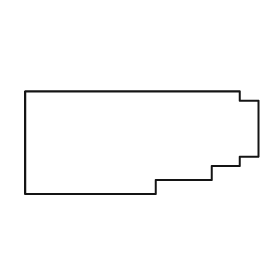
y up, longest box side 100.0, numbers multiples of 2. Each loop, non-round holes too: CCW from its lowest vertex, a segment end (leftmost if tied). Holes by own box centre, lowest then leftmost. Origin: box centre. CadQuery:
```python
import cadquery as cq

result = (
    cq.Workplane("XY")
    .moveTo(-50.0, -22.0)
    .lineTo(6.0, -22.0)
    .lineTo(6.0, -16.0)
    .lineTo(30.0, -16.0)
    .lineTo(30.0, -10.0)
    .lineTo(42.0, -10.0)
    .lineTo(42.0, -6.0)
    .lineTo(50.0, -6.0)
    .lineTo(50.0, 18.0)
    .lineTo(42.0, 18.0)
    .lineTo(42.0, 22.0)
    .lineTo(-50.0, 22.0)
    .close()
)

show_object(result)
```